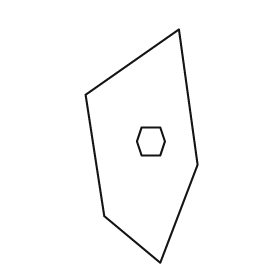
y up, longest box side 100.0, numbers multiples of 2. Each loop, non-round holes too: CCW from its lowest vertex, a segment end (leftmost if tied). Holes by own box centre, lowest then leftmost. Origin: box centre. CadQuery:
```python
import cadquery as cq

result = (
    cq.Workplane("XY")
    .moveTo(8.0, -50.0)
    .lineTo(24.0, -8.0)
    .lineTo(16.0, 50.0)
    .lineTo(-24.0, 22.0)
    .lineTo(-16.0, -30.0)
    .close()
    .moveTo(0.0, -4.0)
    .lineTo(8.0, -4.0)
    .lineTo(10.0, 2.0)
    .lineTo(8.0, 8.0)
    .lineTo(0.0, 8.0)
    .lineTo(-2.0, 2.0)
    .close()
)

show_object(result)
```